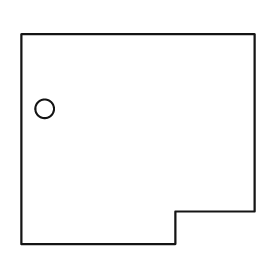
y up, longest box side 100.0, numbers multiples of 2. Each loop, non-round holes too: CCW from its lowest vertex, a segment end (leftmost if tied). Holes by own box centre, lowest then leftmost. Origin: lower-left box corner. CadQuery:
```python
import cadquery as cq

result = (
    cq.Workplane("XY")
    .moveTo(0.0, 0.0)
    .lineTo(66.0, 0.0)
    .lineTo(66.0, 14.0)
    .lineTo(100.0, 14.0)
    .lineTo(100.0, 90.0)
    .lineTo(0.0, 90.0)
    .close()
    .moveTo(10.0, 58.0)
    .circle(4.0)
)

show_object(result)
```